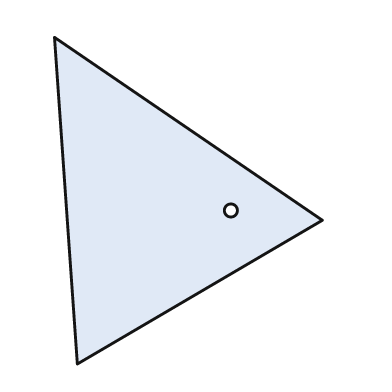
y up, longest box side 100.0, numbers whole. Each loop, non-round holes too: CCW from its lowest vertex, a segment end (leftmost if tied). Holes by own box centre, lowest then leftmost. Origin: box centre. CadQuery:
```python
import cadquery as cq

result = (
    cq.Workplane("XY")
    .moveTo(-34.0, -50.0)
    .lineTo(41.0, -6.0)
    .lineTo(-41.0, 50.0)
    .close()
    .moveTo(13.0, -3.0)
    .circle(2.0)
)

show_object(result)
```